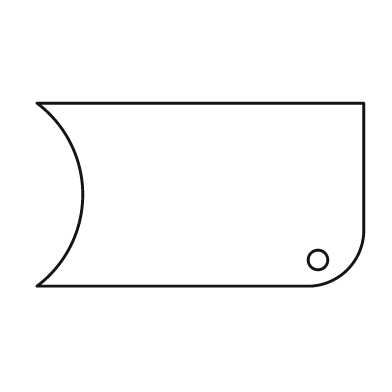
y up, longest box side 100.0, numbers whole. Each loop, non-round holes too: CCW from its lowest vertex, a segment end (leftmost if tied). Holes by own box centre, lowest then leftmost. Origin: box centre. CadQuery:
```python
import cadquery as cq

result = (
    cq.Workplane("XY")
    .moveTo(-50.0, -28.0)
    .lineTo(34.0, -28.0)
    .threePointArc((45.0, -23.0), (50.0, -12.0))
    .lineTo(50.0, 28.0)
    .lineTo(-50.0, 28.0)
    .threePointArc((-36.0, 0.0), (-50.0, -28.0))
    .close()
    .moveTo(36.0, -20.0)
    .circle(3.0)
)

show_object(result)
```